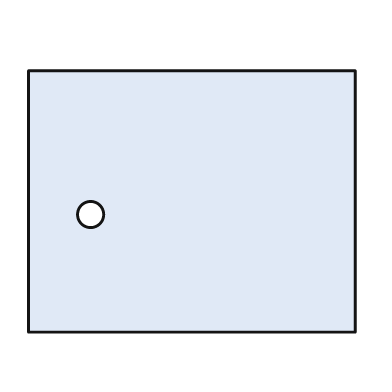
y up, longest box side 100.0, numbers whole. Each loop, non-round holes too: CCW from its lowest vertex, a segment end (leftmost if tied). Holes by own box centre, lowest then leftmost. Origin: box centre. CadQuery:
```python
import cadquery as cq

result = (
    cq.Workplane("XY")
    .moveTo(-50.0, -40.0)
    .lineTo(50.0, -40.0)
    .lineTo(50.0, 40.0)
    .lineTo(-50.0, 40.0)
    .close()
    .moveTo(-31.0, -4.0)
    .circle(4.0)
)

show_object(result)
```